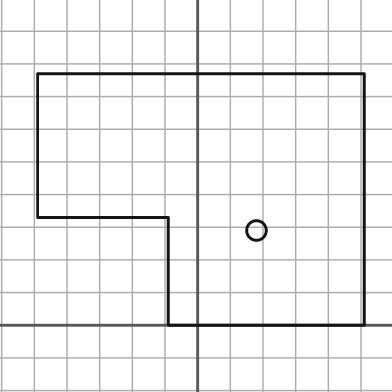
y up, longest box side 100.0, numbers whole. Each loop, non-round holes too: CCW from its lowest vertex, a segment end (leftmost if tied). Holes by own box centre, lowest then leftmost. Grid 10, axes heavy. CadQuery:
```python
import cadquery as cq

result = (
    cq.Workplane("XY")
    .moveTo(-9.0, 0.0)
    .lineTo(51.0, 0.0)
    .lineTo(51.0, 77.0)
    .lineTo(-49.0, 77.0)
    .lineTo(-49.0, 33.0)
    .lineTo(-9.0, 33.0)
    .close()
    .moveTo(18.0, 29.0)
    .circle(3.0)
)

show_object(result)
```